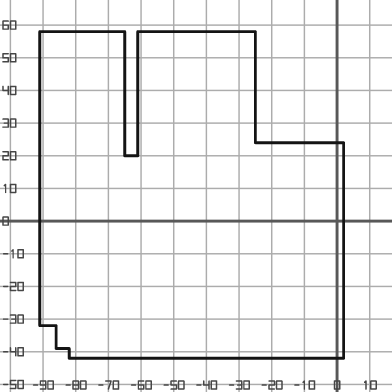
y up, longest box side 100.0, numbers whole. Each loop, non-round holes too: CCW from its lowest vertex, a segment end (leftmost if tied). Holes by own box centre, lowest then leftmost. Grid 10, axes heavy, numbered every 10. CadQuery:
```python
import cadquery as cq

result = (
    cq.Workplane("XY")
    .moveTo(-82.0, -42.0)
    .lineTo(2.0, -42.0)
    .lineTo(2.0, 24.0)
    .lineTo(-25.0, 24.0)
    .lineTo(-25.0, 58.0)
    .lineTo(-61.0, 58.0)
    .lineTo(-61.0, 20.0)
    .lineTo(-65.0, 20.0)
    .lineTo(-65.0, 58.0)
    .lineTo(-91.0, 58.0)
    .lineTo(-91.0, -32.0)
    .lineTo(-86.0, -32.0)
    .lineTo(-86.0, -39.0)
    .lineTo(-82.0, -39.0)
    .close()
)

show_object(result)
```